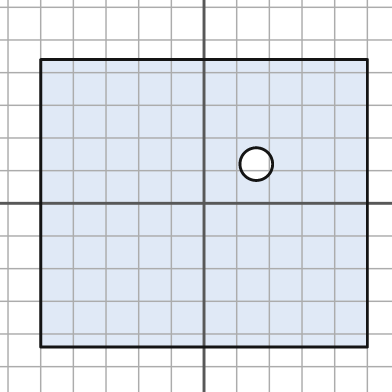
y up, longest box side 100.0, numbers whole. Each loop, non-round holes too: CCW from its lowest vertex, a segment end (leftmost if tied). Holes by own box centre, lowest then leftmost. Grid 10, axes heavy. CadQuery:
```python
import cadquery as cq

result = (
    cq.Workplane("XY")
    .moveTo(-50.0, -44.0)
    .lineTo(50.0, -44.0)
    .lineTo(50.0, 44.0)
    .lineTo(-50.0, 44.0)
    .close()
    .moveTo(16.0, 12.0)
    .circle(5.0)
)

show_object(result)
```